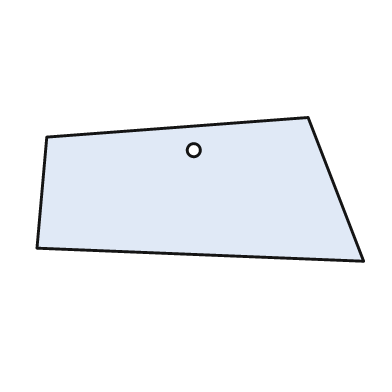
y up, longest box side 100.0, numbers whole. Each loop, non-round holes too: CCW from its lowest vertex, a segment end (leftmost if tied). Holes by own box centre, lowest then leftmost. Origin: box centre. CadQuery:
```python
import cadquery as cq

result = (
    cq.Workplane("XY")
    .moveTo(50.0, -22.0)
    .lineTo(33.0, 22.0)
    .lineTo(-47.0, 16.0)
    .lineTo(-50.0, -18.0)
    .close()
    .moveTo(-2.0, 12.0)
    .circle(2.0)
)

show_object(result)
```